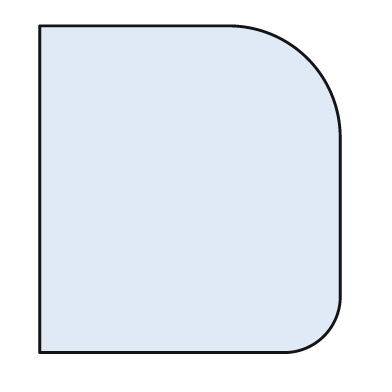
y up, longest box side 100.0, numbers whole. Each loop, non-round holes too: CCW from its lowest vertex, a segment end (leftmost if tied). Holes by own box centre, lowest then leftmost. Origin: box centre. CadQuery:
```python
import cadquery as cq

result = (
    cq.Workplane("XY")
    .moveTo(-46.0, -50.0)
    .lineTo(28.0, -50.0)
    .threePointArc((41.0, -45.0), (46.0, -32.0))
    .lineTo(46.0, 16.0)
    .threePointArc((36.0, 40.0), (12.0, 50.0))
    .lineTo(-46.0, 50.0)
    .close()
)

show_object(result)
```